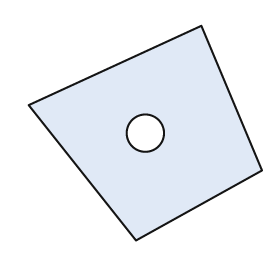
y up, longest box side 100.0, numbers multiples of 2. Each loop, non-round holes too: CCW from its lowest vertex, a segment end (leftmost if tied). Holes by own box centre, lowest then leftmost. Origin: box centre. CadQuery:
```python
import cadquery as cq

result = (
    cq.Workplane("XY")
    .moveTo(-4.0, -46.0)
    .lineTo(50.0, -16.0)
    .lineTo(24.0, 46.0)
    .lineTo(-50.0, 12.0)
    .close()
    .moveTo(0.0, 0.0)
    .circle(8.0)
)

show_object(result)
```